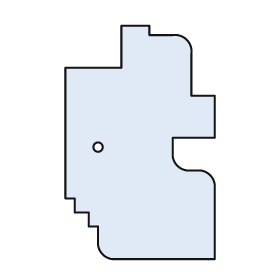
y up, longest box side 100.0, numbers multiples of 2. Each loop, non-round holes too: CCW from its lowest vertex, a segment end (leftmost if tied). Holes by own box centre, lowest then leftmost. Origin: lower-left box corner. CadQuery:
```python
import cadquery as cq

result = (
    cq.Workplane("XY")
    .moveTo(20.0, 0.0)
    .lineTo(64.0, 0.0)
    .lineTo(64.0, 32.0)
    .threePointArc((62.0, 36.0), (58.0, 38.0))
    .lineTo(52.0, 38.0)
    .threePointArc((48.0, 40.0), (46.0, 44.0))
    .lineTo(46.0, 52.0)
    .lineTo(64.0, 52.0)
    .lineTo(64.0, 70.0)
    .lineTo(54.0, 70.0)
    .lineTo(54.0, 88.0)
    .threePointArc((52.0, 94.0), (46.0, 96.0))
    .lineTo(36.0, 96.0)
    .lineTo(36.0, 100.0)
    .lineTo(24.0, 100.0)
    .lineTo(24.0, 82.0)
    .lineTo(0.0, 82.0)
    .lineTo(0.0, 26.0)
    .lineTo(4.0, 26.0)
    .lineTo(4.0, 20.0)
    .lineTo(10.0, 20.0)
    .lineTo(10.0, 14.0)
    .lineTo(14.0, 14.0)
    .lineTo(14.0, 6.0)
    .threePointArc((16.0, 2.0), (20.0, 0.0))
    .close()
    .moveTo(14.0, 48.0)
    .circle(2.0)
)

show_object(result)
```